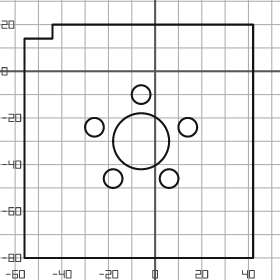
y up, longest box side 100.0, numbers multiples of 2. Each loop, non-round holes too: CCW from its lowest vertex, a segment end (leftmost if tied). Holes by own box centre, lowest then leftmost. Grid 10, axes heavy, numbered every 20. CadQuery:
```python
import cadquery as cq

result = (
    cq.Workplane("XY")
    .moveTo(-56.0, -80.0)
    .lineTo(42.0, -80.0)
    .lineTo(42.0, 20.0)
    .lineTo(-44.0, 20.0)
    .lineTo(-44.0, 14.0)
    .lineTo(-56.0, 14.0)
    .close()
    .moveTo(-18.0, -46.0)
    .circle(4.0)
    .moveTo(6.0, -46.0)
    .circle(4.0)
    .moveTo(-6.0, -30.0)
    .circle(12.0)
    .moveTo(-26.0, -24.0)
    .circle(4.0)
    .moveTo(14.0, -24.0)
    .circle(4.0)
    .moveTo(-6.0, -10.0)
    .circle(4.0)
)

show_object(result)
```